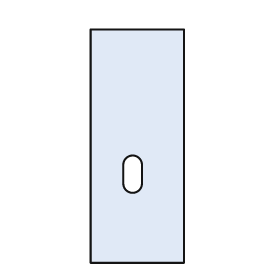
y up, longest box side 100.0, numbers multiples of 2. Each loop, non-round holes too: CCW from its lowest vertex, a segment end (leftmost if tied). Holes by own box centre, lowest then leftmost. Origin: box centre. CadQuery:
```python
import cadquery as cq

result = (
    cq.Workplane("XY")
    .moveTo(-20.0, -50.0)
    .lineTo(20.0, -50.0)
    .lineTo(20.0, 50.0)
    .lineTo(-20.0, 50.0)
    .close()
    .moveTo(-6.0, -16.0)
    .threePointArc((-2.0, -20.0), (2.0, -16.0))
    .lineTo(2.0, -8.0)
    .threePointArc((-2.0, -4.0), (-6.0, -8.0))
    .close()
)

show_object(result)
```